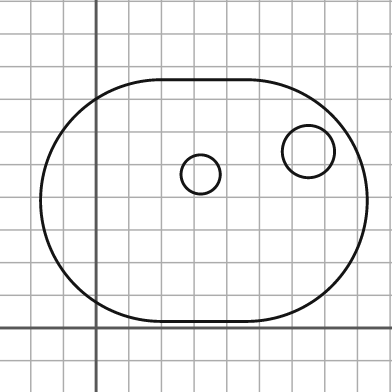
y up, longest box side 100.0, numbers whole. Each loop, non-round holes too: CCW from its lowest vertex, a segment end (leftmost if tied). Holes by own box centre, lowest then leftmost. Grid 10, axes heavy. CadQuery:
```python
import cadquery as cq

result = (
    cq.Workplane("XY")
    .moveTo(20.0, 2.0)
    .lineTo(46.0, 2.0)
    .threePointArc((83.0, 39.0), (46.0, 76.0))
    .lineTo(20.0, 76.0)
    .threePointArc((-17.0, 39.0), (20.0, 2.0))
    .close()
    .moveTo(32.0, 47.0)
    .circle(6.0)
    .moveTo(65.0, 54.0)
    .circle(8.0)
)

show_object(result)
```